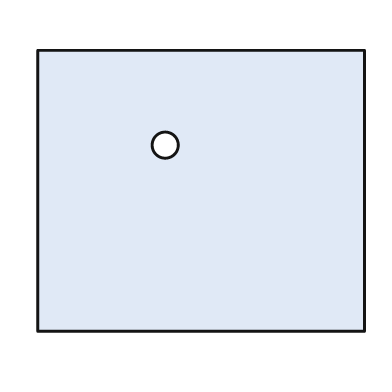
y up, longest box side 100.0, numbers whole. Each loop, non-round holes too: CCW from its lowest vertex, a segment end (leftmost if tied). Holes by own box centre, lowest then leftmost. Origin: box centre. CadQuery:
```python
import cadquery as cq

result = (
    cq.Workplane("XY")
    .moveTo(-50.0, -43.0)
    .lineTo(50.0, -43.0)
    .lineTo(50.0, 43.0)
    .lineTo(-50.0, 43.0)
    .close()
    .moveTo(-11.0, 14.0)
    .circle(4.0)
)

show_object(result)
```